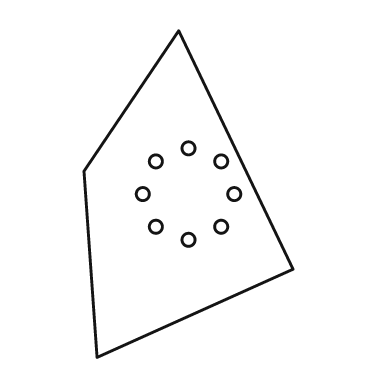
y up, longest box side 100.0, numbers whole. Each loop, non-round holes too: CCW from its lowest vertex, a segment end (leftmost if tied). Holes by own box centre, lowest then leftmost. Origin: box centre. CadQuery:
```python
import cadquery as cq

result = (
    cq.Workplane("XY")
    .moveTo(-28.0, -50.0)
    .lineTo(32.0, -23.0)
    .lineTo(-3.0, 50.0)
    .lineTo(-32.0, 7.0)
    .close()
    .moveTo(0.0, -14.0)
    .circle(2.0)
    .moveTo(-10.0, -10.0)
    .circle(2.0)
    .moveTo(10.0, -10.0)
    .circle(2.0)
    .moveTo(-14.0, 0.0)
    .circle(2.0)
    .moveTo(14.0, 0.0)
    .circle(2.0)
    .moveTo(-10.0, 10.0)
    .circle(2.0)
    .moveTo(10.0, 10.0)
    .circle(2.0)
    .moveTo(0.0, 14.0)
    .circle(2.0)
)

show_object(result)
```